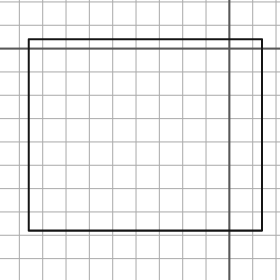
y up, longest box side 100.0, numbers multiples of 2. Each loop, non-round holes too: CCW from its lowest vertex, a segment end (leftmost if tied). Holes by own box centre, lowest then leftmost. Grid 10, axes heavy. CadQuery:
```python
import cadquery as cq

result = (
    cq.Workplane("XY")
    .moveTo(-86.0, -78.0)
    .lineTo(14.0, -78.0)
    .lineTo(14.0, 4.0)
    .lineTo(-86.0, 4.0)
    .close()
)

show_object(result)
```